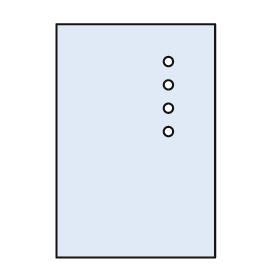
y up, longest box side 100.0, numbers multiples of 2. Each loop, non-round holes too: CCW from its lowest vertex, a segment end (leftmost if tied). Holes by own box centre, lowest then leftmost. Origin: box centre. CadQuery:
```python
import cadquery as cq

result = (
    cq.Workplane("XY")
    .moveTo(-34.0, -50.0)
    .lineTo(34.0, -50.0)
    .lineTo(34.0, 50.0)
    .lineTo(-34.0, 50.0)
    .close()
    .moveTo(14.0, 4.0)
    .circle(2.0)
    .moveTo(14.0, 14.0)
    .circle(2.0)
    .moveTo(14.0, 24.0)
    .circle(2.0)
    .moveTo(14.0, 34.0)
    .circle(2.0)
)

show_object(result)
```